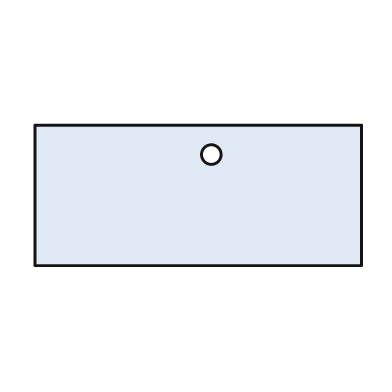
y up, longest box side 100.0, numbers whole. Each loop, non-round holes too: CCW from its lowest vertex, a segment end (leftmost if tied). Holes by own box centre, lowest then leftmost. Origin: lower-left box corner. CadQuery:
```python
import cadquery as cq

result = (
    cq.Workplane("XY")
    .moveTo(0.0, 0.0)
    .lineTo(100.0, 0.0)
    .lineTo(100.0, 43.0)
    .lineTo(0.0, 43.0)
    .close()
    .moveTo(54.0, 34.0)
    .circle(3.0)
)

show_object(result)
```